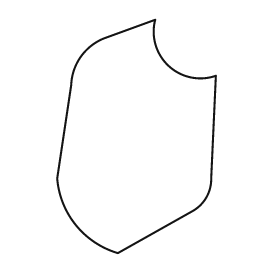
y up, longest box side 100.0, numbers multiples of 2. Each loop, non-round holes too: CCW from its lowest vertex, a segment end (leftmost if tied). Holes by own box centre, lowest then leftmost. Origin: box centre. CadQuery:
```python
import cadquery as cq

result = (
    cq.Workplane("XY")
    .moveTo(-8.0, -50.0)
    .lineTo(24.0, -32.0)
    .threePointArc((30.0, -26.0), (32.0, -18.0))
    .lineTo(34.0, 26.0)
    .threePointArc((14.0, 30.0), (8.0, 50.0))
    .lineTo(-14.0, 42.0)
    .threePointArc((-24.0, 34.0), (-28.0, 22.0))
    .lineTo(-34.0, -18.0)
    .threePointArc((-26.0, -38.0), (-8.0, -50.0))
    .close()
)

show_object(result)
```